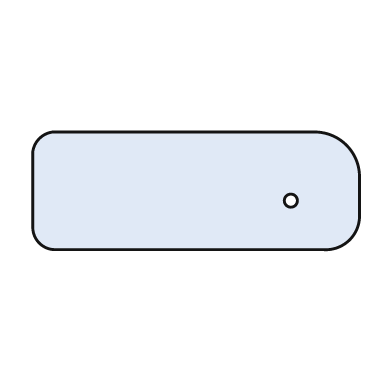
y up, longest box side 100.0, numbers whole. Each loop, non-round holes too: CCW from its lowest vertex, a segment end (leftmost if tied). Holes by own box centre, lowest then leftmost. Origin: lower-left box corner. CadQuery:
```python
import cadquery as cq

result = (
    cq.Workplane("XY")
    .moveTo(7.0, 0.0)
    .lineTo(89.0, 0.0)
    .threePointArc((97.0, 3.0), (100.0, 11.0))
    .lineTo(100.0, 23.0)
    .threePointArc((96.0, 32.0), (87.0, 36.0))
    .lineTo(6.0, 36.0)
    .threePointArc((2.0, 34.0), (0.0, 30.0))
    .lineTo(0.0, 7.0)
    .threePointArc((2.0, 2.0), (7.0, 0.0))
    .close()
    .moveTo(79.0, 15.0)
    .circle(2.0)
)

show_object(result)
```